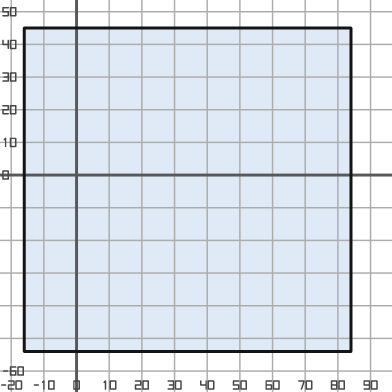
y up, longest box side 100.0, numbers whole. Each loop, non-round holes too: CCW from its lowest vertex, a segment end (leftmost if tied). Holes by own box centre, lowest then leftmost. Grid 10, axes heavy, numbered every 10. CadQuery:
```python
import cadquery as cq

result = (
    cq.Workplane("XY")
    .moveTo(-16.0, -54.0)
    .lineTo(84.0, -54.0)
    .lineTo(84.0, 45.0)
    .lineTo(-16.0, 45.0)
    .close()
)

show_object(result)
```